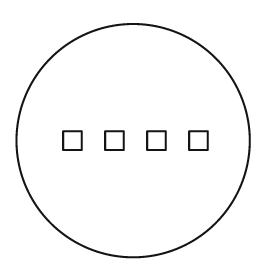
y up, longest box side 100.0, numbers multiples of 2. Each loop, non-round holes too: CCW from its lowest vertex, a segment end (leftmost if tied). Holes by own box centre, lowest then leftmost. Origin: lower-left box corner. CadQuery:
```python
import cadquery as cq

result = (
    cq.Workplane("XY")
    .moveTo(50.0, 50.0)
    .circle(50.0)
    .moveTo(20.0, 46.0)
    .lineTo(28.0, 46.0)
    .lineTo(28.0, 54.0)
    .lineTo(20.0, 54.0)
    .close()
    .moveTo(38.0, 46.0)
    .lineTo(46.0, 46.0)
    .lineTo(46.0, 54.0)
    .lineTo(38.0, 54.0)
    .close()
    .moveTo(56.0, 46.0)
    .lineTo(64.0, 46.0)
    .lineTo(64.0, 54.0)
    .lineTo(56.0, 54.0)
    .close()
    .moveTo(74.0, 46.0)
    .lineTo(82.0, 46.0)
    .lineTo(82.0, 54.0)
    .lineTo(74.0, 54.0)
    .close()
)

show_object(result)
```